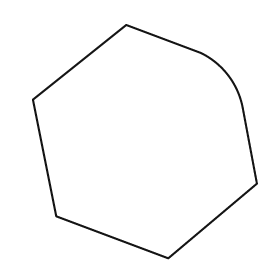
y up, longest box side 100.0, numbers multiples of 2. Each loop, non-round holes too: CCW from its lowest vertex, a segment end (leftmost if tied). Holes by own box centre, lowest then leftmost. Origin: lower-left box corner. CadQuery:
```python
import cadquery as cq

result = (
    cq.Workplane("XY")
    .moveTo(58.0, 0.0)
    .lineTo(96.0, 32.0)
    .lineTo(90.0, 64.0)
    .threePointArc((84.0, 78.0), (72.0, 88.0))
    .lineTo(40.0, 100.0)
    .lineTo(0.0, 68.0)
    .lineTo(10.0, 18.0)
    .close()
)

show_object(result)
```